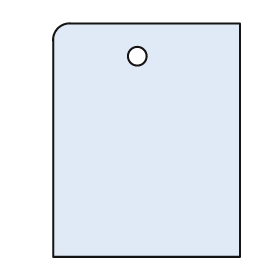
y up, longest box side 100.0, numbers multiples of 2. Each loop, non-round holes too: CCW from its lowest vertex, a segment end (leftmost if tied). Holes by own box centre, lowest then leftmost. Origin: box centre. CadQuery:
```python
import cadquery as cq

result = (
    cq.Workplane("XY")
    .moveTo(-40.0, -50.0)
    .lineTo(40.0, -50.0)
    .lineTo(40.0, 50.0)
    .lineTo(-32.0, 50.0)
    .threePointArc((-38.0, 48.0), (-40.0, 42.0))
    .close()
    .moveTo(-4.0, 36.0)
    .circle(4.0)
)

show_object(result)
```